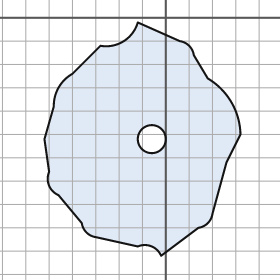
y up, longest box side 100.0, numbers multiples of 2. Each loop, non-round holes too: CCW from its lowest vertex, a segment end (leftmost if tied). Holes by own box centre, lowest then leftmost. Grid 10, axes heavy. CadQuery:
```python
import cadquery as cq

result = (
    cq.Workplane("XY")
    .moveTo(-2.0, -102.0)
    .lineTo(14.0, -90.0)
    .threePointArc((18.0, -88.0), (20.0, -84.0))
    .lineTo(26.0, -62.0)
    .lineTo(32.0, -50.0)
    .threePointArc((28.0, -36.0), (18.0, -26.0))
    .lineTo(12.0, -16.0)
    .threePointArc((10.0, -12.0), (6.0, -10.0))
    .lineTo(-12.0, -2.0)
    .threePointArc((-18.0, -10.0), (-28.0, -12.0))
    .lineTo(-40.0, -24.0)
    .threePointArc((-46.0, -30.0), (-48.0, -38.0))
    .lineTo(-52.0, -52.0)
    .lineTo(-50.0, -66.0)
    .threePointArc((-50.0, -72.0), (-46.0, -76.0))
    .lineTo(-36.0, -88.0)
    .threePointArc((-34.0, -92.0), (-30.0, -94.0))
    .lineTo(-12.0, -98.0)
    .threePointArc((-6.0, -98.0), (-2.0, -102.0))
    .close()
    .moveTo(-6.0, -52.0)
    .circle(6.0)
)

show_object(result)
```